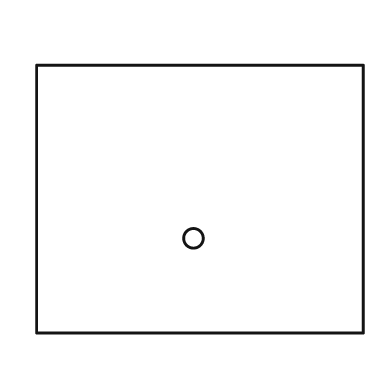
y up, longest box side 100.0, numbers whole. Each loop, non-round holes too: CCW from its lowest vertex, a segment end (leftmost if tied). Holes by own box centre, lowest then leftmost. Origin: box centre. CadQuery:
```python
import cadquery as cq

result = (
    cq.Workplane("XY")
    .moveTo(-50.0, -41.0)
    .lineTo(50.0, -41.0)
    .lineTo(50.0, 41.0)
    .lineTo(-50.0, 41.0)
    .close()
    .moveTo(-2.0, -12.0)
    .circle(3.0)
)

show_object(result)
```